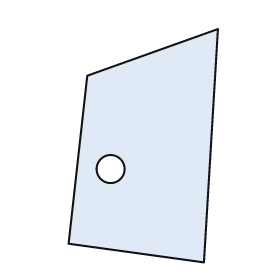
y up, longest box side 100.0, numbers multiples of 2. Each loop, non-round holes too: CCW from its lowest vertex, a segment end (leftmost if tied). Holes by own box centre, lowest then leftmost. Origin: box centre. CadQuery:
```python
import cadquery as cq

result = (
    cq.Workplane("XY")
    .moveTo(26.0, -50.0)
    .lineTo(32.0, 50.0)
    .lineTo(-24.0, 30.0)
    .lineTo(-32.0, -42.0)
    .close()
    .moveTo(-14.0, -10.0)
    .circle(6.0)
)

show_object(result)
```